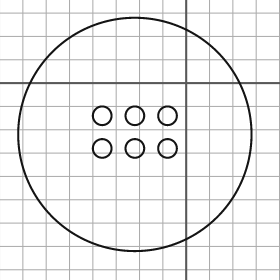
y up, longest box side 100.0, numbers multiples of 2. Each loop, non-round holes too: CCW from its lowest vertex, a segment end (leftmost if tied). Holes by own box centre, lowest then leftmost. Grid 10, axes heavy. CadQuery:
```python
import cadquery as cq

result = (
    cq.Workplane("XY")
    .moveTo(-22.0, -22.0)
    .circle(50.0)
    .moveTo(-36.0, -28.0)
    .circle(4.0)
    .moveTo(-22.0, -28.0)
    .circle(4.0)
    .moveTo(-8.0, -28.0)
    .circle(4.0)
    .moveTo(-36.0, -14.0)
    .circle(4.0)
    .moveTo(-22.0, -14.0)
    .circle(4.0)
    .moveTo(-8.0, -14.0)
    .circle(4.0)
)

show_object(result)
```